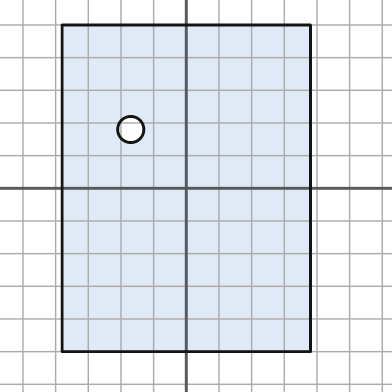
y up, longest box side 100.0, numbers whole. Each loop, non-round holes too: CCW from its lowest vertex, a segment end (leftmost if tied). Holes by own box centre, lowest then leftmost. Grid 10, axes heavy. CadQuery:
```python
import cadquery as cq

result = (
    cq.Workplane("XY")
    .moveTo(-38.0, -50.0)
    .lineTo(38.0, -50.0)
    .lineTo(38.0, 50.0)
    .lineTo(-38.0, 50.0)
    .close()
    .moveTo(-17.0, 18.0)
    .circle(4.0)
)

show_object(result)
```